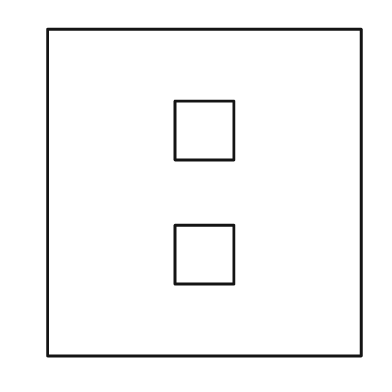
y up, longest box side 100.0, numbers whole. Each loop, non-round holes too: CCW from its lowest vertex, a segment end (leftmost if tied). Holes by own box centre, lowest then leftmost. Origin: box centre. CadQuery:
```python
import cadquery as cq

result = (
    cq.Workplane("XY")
    .moveTo(-48.0, -50.0)
    .lineTo(48.0, -50.0)
    .lineTo(48.0, 50.0)
    .lineTo(-48.0, 50.0)
    .close()
    .moveTo(-9.0, -28.0)
    .lineTo(9.0, -28.0)
    .lineTo(9.0, -10.0)
    .lineTo(-9.0, -10.0)
    .close()
    .moveTo(-9.0, 10.0)
    .lineTo(9.0, 10.0)
    .lineTo(9.0, 28.0)
    .lineTo(-9.0, 28.0)
    .close()
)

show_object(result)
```